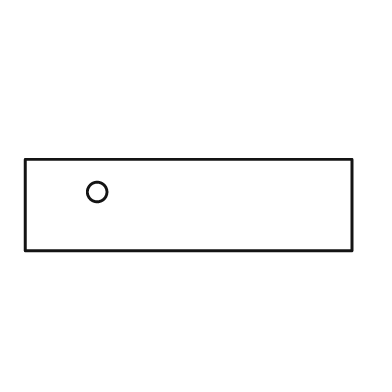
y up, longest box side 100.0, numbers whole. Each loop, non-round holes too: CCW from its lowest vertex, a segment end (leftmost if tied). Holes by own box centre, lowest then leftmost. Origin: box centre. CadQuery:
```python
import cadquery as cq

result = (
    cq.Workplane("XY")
    .moveTo(-50.0, -14.0)
    .lineTo(50.0, -14.0)
    .lineTo(50.0, 14.0)
    .lineTo(-50.0, 14.0)
    .close()
    .moveTo(-28.0, 4.0)
    .circle(3.0)
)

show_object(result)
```